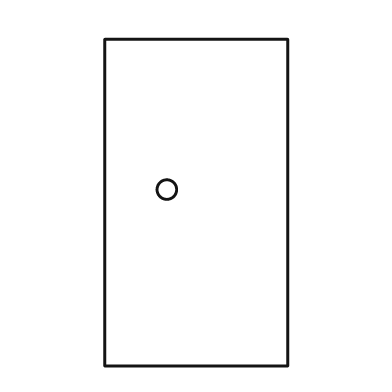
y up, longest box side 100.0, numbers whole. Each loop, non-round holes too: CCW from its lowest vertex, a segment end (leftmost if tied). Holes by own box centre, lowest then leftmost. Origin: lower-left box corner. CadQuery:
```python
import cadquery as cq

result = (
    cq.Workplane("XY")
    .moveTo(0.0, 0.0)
    .lineTo(56.0, 0.0)
    .lineTo(56.0, 100.0)
    .lineTo(0.0, 100.0)
    .close()
    .moveTo(19.0, 54.0)
    .circle(3.0)
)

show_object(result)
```